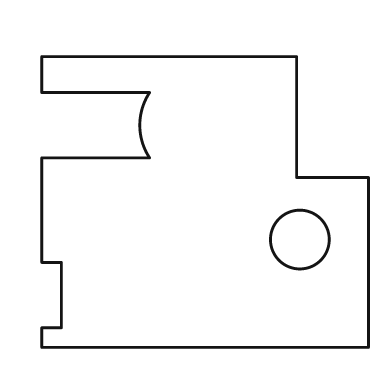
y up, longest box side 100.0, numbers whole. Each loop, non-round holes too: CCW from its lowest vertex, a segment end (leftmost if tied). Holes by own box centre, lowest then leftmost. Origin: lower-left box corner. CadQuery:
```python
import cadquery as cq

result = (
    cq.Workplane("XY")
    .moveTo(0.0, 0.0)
    .lineTo(100.0, 0.0)
    .lineTo(100.0, 52.0)
    .lineTo(78.0, 52.0)
    .lineTo(78.0, 89.0)
    .lineTo(0.0, 89.0)
    .lineTo(0.0, 78.0)
    .lineTo(33.0, 78.0)
    .threePointArc((30.0, 68.0), (33.0, 58.0))
    .lineTo(0.0, 58.0)
    .lineTo(0.0, 26.0)
    .lineTo(6.0, 26.0)
    .lineTo(6.0, 6.0)
    .lineTo(0.0, 6.0)
    .close()
    .moveTo(79.0, 33.0)
    .circle(9.0)
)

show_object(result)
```